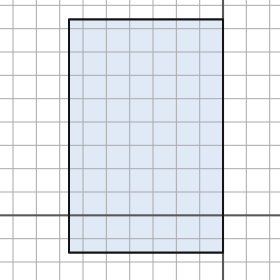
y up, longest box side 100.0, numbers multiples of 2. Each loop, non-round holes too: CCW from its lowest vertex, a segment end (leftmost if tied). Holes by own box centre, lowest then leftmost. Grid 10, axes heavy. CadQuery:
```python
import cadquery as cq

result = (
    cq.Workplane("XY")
    .moveTo(-66.0, -16.0)
    .lineTo(0.0, -16.0)
    .lineTo(0.0, 84.0)
    .lineTo(-66.0, 84.0)
    .close()
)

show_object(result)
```